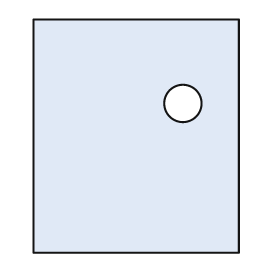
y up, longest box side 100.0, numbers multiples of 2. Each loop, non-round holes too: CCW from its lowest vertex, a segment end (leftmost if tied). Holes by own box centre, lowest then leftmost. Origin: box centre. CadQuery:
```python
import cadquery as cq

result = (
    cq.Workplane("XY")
    .moveTo(-44.0, -50.0)
    .lineTo(44.0, -50.0)
    .lineTo(44.0, 50.0)
    .lineTo(-44.0, 50.0)
    .close()
    .moveTo(20.0, 14.0)
    .circle(8.0)
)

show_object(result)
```